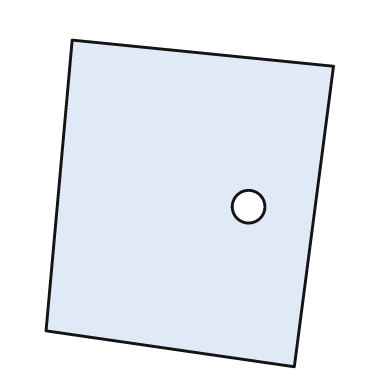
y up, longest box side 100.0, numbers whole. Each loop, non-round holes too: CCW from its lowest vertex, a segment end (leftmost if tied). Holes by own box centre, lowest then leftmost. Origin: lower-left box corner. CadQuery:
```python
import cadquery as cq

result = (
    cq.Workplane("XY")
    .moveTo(76.0, 0.0)
    .lineTo(88.0, 92.0)
    .lineTo(8.0, 100.0)
    .lineTo(0.0, 11.0)
    .close()
    .moveTo(62.0, 49.0)
    .circle(5.0)
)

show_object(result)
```